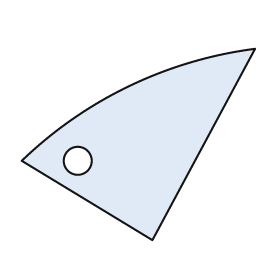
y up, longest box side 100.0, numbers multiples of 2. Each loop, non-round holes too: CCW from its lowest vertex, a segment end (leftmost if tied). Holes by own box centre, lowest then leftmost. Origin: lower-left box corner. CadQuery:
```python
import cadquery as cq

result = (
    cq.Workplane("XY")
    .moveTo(56.0, 0.0)
    .lineTo(100.0, 82.0)
    .threePointArc((46.0, 66.0), (0.0, 34.0))
    .close()
    .moveTo(24.0, 34.0)
    .circle(6.0)
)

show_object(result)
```